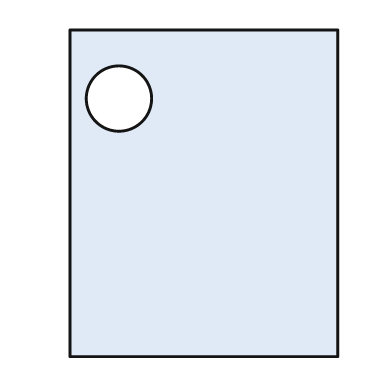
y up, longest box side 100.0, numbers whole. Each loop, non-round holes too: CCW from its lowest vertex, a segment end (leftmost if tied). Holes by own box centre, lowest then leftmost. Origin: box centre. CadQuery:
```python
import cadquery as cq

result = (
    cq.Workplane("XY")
    .moveTo(-41.0, -50.0)
    .lineTo(41.0, -50.0)
    .lineTo(41.0, 50.0)
    .lineTo(-41.0, 50.0)
    .close()
    .moveTo(-26.0, 29.0)
    .circle(10.0)
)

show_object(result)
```